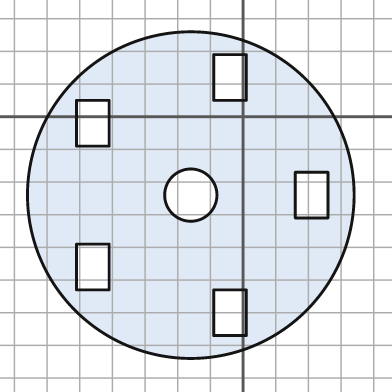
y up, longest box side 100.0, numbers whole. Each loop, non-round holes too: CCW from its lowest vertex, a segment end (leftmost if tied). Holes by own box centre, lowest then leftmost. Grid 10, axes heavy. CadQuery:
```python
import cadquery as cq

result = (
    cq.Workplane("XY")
    .moveTo(-16.0, -24.0)
    .circle(50.0)
    .moveTo(-9.0, -67.0)
    .lineTo(1.0, -67.0)
    .lineTo(1.0, -53.0)
    .lineTo(-9.0, -53.0)
    .close()
    .moveTo(-51.0, -53.0)
    .lineTo(-41.0, -53.0)
    .lineTo(-41.0, -39.0)
    .lineTo(-51.0, -39.0)
    .close()
    .moveTo(-16.0, -24.0)
    .circle(8.0)
    .moveTo(16.0, -31.0)
    .lineTo(26.0, -31.0)
    .lineTo(26.0, -17.0)
    .lineTo(16.0, -17.0)
    .close()
    .moveTo(-51.0, -9.0)
    .lineTo(-41.0, -9.0)
    .lineTo(-41.0, 5.0)
    .lineTo(-51.0, 5.0)
    .close()
    .moveTo(-9.0, 5.0)
    .lineTo(1.0, 5.0)
    .lineTo(1.0, 19.0)
    .lineTo(-9.0, 19.0)
    .close()
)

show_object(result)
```